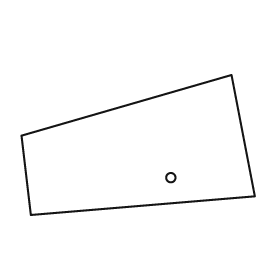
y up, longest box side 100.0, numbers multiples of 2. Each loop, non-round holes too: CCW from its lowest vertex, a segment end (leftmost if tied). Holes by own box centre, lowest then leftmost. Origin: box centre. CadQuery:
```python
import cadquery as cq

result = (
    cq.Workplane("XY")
    .moveTo(-46.0, -30.0)
    .lineTo(50.0, -22.0)
    .lineTo(40.0, 30.0)
    .lineTo(-50.0, 4.0)
    .close()
    .moveTo(14.0, -14.0)
    .circle(2.0)
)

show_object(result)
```